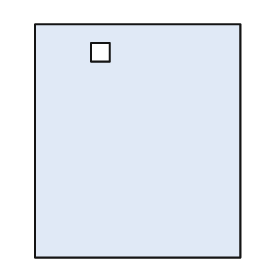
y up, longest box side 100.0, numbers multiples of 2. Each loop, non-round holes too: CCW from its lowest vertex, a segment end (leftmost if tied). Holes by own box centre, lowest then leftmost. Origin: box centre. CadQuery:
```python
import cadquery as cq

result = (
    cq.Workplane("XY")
    .moveTo(-44.0, -50.0)
    .lineTo(44.0, -50.0)
    .lineTo(44.0, 50.0)
    .lineTo(-44.0, 50.0)
    .close()
    .moveTo(-20.0, 34.0)
    .lineTo(-12.0, 34.0)
    .lineTo(-12.0, 42.0)
    .lineTo(-20.0, 42.0)
    .close()
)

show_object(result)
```